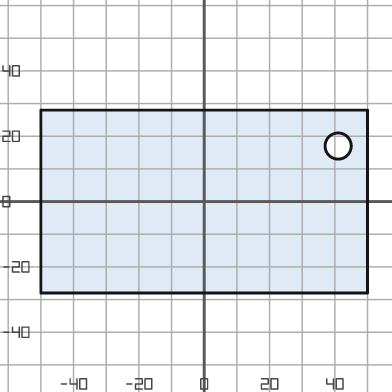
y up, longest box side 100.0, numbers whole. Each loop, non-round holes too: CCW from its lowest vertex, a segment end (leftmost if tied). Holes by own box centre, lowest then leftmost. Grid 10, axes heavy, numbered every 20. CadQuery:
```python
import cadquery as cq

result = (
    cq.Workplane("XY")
    .moveTo(-50.0, -28.0)
    .lineTo(50.0, -28.0)
    .lineTo(50.0, 28.0)
    .lineTo(-50.0, 28.0)
    .close()
    .moveTo(41.0, 17.0)
    .circle(4.0)
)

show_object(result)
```